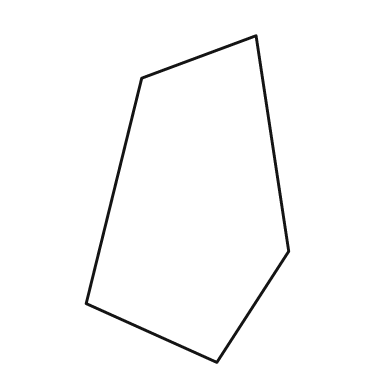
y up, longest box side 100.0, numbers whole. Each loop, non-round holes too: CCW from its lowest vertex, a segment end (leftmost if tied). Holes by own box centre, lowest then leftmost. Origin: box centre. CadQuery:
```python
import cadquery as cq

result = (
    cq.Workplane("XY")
    .moveTo(9.0, -50.0)
    .lineTo(31.0, -16.0)
    .lineTo(21.0, 50.0)
    .lineTo(-14.0, 37.0)
    .lineTo(-31.0, -32.0)
    .close()
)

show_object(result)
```